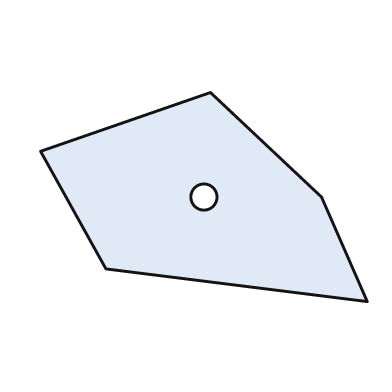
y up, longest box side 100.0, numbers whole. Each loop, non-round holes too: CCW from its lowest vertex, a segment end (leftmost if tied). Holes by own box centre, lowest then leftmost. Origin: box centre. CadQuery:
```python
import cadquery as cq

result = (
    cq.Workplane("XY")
    .moveTo(50.0, -32.0)
    .lineTo(36.0, 0.0)
    .lineTo(2.0, 32.0)
    .lineTo(-50.0, 14.0)
    .lineTo(-30.0, -22.0)
    .close()
    .moveTo(0.0, 0.0)
    .circle(4.0)
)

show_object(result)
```